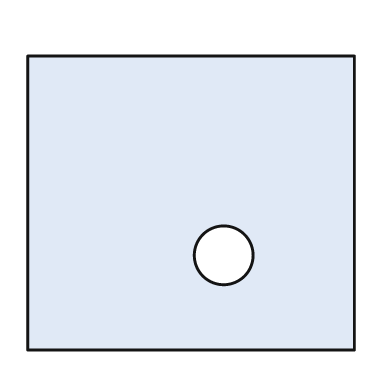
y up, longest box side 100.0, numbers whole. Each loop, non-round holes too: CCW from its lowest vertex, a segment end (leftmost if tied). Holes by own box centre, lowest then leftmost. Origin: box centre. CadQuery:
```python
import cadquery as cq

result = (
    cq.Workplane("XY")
    .moveTo(-50.0, -45.0)
    .lineTo(50.0, -45.0)
    .lineTo(50.0, 45.0)
    .lineTo(-50.0, 45.0)
    .close()
    .moveTo(10.0, -16.0)
    .circle(9.0)
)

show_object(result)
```